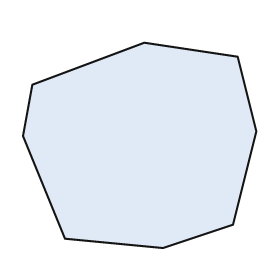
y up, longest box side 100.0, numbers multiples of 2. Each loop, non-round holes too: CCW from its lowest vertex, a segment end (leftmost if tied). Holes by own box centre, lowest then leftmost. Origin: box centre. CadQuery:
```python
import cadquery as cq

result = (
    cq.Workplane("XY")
    .moveTo(10.0, -44.0)
    .lineTo(40.0, -34.0)
    .lineTo(50.0, 6.0)
    .lineTo(42.0, 38.0)
    .lineTo(2.0, 44.0)
    .lineTo(-46.0, 26.0)
    .lineTo(-50.0, 4.0)
    .lineTo(-32.0, -40.0)
    .close()
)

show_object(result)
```